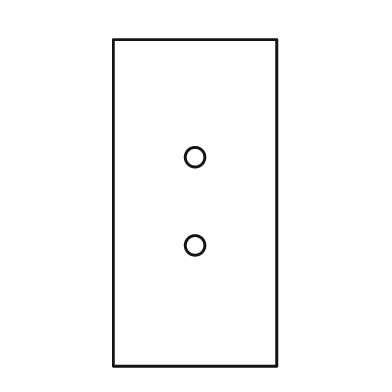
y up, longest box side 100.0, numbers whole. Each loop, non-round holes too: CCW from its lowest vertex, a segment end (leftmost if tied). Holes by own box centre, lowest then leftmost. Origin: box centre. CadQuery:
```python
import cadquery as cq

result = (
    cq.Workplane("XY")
    .moveTo(-25.0, -50.0)
    .lineTo(25.0, -50.0)
    .lineTo(25.0, 50.0)
    .lineTo(-25.0, 50.0)
    .close()
    .moveTo(0.0, -13.0)
    .circle(3.0)
    .moveTo(0.0, 14.0)
    .circle(3.0)
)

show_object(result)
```